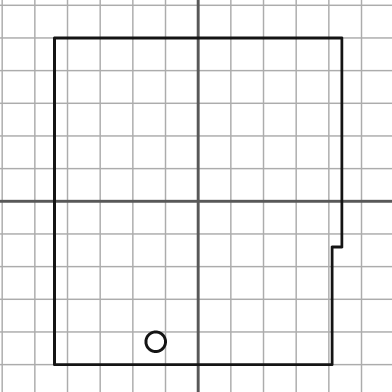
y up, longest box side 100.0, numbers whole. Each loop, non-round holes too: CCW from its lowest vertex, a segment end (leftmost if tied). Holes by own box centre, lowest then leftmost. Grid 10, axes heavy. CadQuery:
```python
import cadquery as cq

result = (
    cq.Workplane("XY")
    .moveTo(-44.0, -50.0)
    .lineTo(41.0, -50.0)
    .lineTo(41.0, -14.0)
    .lineTo(44.0, -14.0)
    .lineTo(44.0, 50.0)
    .lineTo(-44.0, 50.0)
    .close()
    .moveTo(-13.0, -43.0)
    .circle(3.0)
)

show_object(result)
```